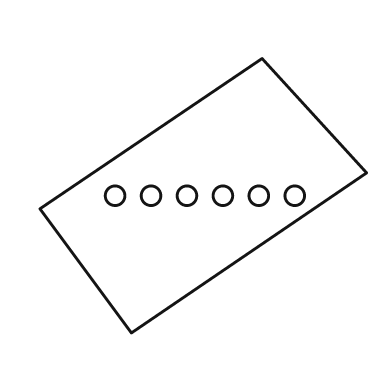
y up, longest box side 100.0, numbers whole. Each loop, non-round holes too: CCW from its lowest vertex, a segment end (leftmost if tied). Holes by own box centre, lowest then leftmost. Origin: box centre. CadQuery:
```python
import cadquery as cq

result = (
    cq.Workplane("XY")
    .moveTo(-22.0, -42.0)
    .lineTo(50.0, 7.0)
    .lineTo(18.0, 42.0)
    .lineTo(-50.0, -4.0)
    .close()
    .moveTo(-27.0, 0.0)
    .circle(3.0)
    .moveTo(-16.0, 0.0)
    .circle(3.0)
    .moveTo(-5.0, 0.0)
    .circle(3.0)
    .moveTo(6.0, 0.0)
    .circle(3.0)
    .moveTo(17.0, 0.0)
    .circle(3.0)
    .moveTo(28.0, 0.0)
    .circle(3.0)
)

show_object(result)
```